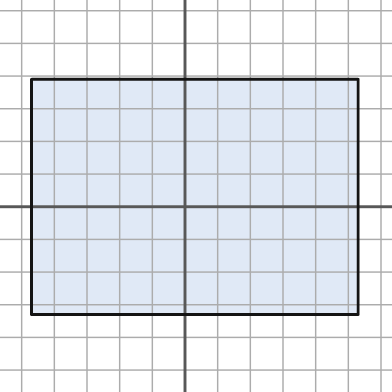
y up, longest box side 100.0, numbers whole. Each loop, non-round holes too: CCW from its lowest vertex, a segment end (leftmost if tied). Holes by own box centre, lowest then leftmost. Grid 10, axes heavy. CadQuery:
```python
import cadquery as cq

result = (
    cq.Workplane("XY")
    .moveTo(-47.0, -33.0)
    .lineTo(53.0, -33.0)
    .lineTo(53.0, 39.0)
    .lineTo(-47.0, 39.0)
    .close()
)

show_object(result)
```